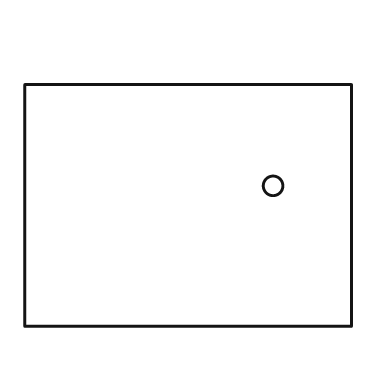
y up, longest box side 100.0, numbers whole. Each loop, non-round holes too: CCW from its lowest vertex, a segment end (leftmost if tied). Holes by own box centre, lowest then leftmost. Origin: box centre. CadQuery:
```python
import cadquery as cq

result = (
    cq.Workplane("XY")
    .moveTo(-50.0, -37.0)
    .lineTo(50.0, -37.0)
    .lineTo(50.0, 37.0)
    .lineTo(-50.0, 37.0)
    .close()
    .moveTo(26.0, 6.0)
    .circle(3.0)
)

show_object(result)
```